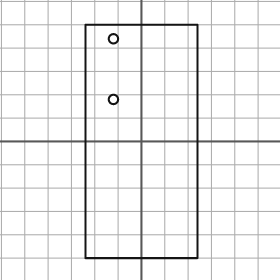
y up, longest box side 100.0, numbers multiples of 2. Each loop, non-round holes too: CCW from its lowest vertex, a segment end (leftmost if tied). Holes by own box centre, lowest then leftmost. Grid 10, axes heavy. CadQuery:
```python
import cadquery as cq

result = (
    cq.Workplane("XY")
    .moveTo(-24.0, -50.0)
    .lineTo(24.0, -50.0)
    .lineTo(24.0, 50.0)
    .lineTo(-24.0, 50.0)
    .close()
    .moveTo(-12.0, 18.0)
    .circle(2.0)
    .moveTo(-12.0, 44.0)
    .circle(2.0)
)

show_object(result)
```